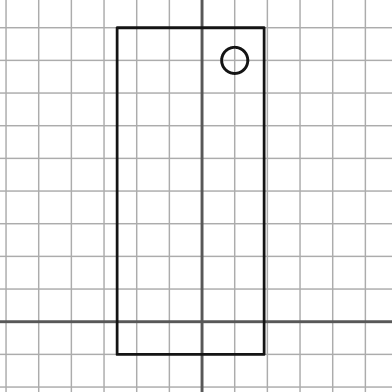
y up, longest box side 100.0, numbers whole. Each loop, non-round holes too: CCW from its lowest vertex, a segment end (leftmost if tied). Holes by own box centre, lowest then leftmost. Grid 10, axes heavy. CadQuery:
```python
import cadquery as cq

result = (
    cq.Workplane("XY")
    .moveTo(-26.0, -10.0)
    .lineTo(19.0, -10.0)
    .lineTo(19.0, 90.0)
    .lineTo(-26.0, 90.0)
    .close()
    .moveTo(10.0, 80.0)
    .circle(4.0)
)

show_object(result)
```